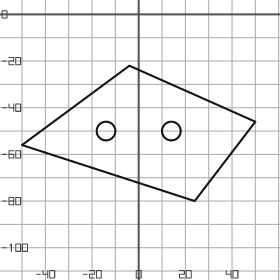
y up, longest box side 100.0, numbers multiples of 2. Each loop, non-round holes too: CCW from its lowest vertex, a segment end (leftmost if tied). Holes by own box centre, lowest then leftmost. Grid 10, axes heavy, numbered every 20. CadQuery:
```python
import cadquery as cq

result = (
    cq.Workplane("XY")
    .moveTo(24.0, -80.0)
    .lineTo(50.0, -46.0)
    .lineTo(-4.0, -22.0)
    .lineTo(-50.0, -56.0)
    .close()
    .moveTo(-14.0, -50.0)
    .circle(4.0)
    .moveTo(14.0, -50.0)
    .circle(4.0)
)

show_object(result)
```